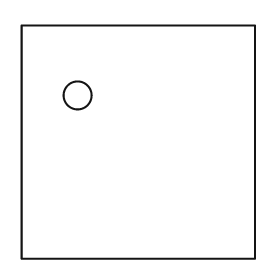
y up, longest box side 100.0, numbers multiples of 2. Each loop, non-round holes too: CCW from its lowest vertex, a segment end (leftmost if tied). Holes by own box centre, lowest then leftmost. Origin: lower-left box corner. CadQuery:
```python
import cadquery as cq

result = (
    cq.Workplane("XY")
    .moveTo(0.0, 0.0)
    .lineTo(100.0, 0.0)
    .lineTo(100.0, 100.0)
    .lineTo(0.0, 100.0)
    .close()
    .moveTo(24.0, 70.0)
    .circle(6.0)
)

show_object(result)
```